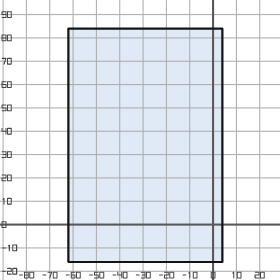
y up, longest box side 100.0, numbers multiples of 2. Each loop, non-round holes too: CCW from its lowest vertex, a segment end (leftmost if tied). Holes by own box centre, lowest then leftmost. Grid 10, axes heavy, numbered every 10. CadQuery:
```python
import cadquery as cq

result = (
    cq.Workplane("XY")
    .moveTo(-62.0, -16.0)
    .lineTo(4.0, -16.0)
    .lineTo(4.0, 84.0)
    .lineTo(-62.0, 84.0)
    .close()
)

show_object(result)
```